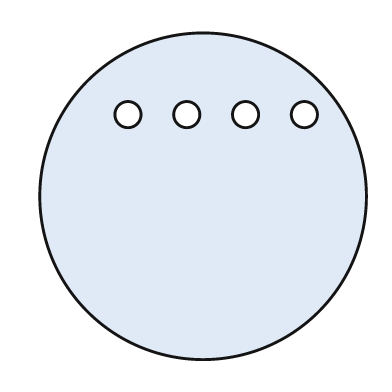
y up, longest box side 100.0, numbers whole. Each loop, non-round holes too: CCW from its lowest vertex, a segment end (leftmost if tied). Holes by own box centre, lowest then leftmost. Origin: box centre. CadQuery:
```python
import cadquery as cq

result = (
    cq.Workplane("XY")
    .moveTo(0.0, 0.0)
    .circle(50.0)
    .moveTo(-23.0, 25.0)
    .circle(4.0)
    .moveTo(-5.0, 25.0)
    .circle(4.0)
    .moveTo(13.0, 25.0)
    .circle(4.0)
    .moveTo(31.0, 25.0)
    .circle(4.0)
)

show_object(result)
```